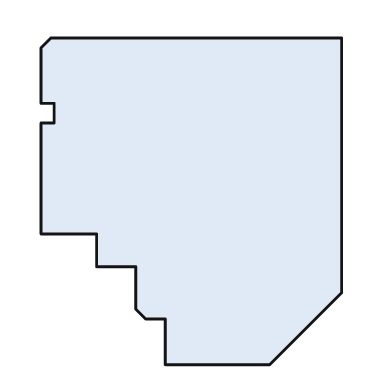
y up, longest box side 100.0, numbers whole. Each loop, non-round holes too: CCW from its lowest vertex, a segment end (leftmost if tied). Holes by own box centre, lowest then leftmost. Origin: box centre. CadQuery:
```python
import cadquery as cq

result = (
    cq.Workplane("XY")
    .moveTo(-8.0, -50.0)
    .lineTo(24.0, -50.0)
    .lineTo(46.0, -28.0)
    .lineTo(46.0, 50.0)
    .lineTo(-43.0, 50.0)
    .lineTo(-46.0, 47.0)
    .lineTo(-46.0, 30.0)
    .lineTo(-42.0, 30.0)
    .lineTo(-42.0, 24.0)
    .lineTo(-46.0, 24.0)
    .lineTo(-46.0, -10.0)
    .lineTo(-29.0, -10.0)
    .lineTo(-29.0, -20.0)
    .lineTo(-17.0, -20.0)
    .lineTo(-17.0, -33.0)
    .lineTo(-14.0, -36.0)
    .lineTo(-8.0, -36.0)
    .close()
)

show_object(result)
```